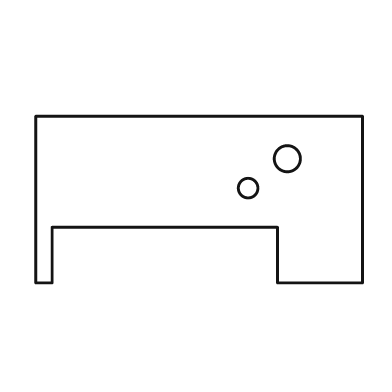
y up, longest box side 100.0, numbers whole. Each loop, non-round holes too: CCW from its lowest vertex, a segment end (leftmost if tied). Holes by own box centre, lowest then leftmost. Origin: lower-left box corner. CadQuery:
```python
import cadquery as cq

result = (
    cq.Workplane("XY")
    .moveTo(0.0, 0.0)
    .lineTo(5.0, 0.0)
    .lineTo(5.0, 17.0)
    .lineTo(74.0, 17.0)
    .lineTo(74.0, 0.0)
    .lineTo(100.0, 0.0)
    .lineTo(100.0, 51.0)
    .lineTo(0.0, 51.0)
    .close()
    .moveTo(65.0, 29.0)
    .circle(3.0)
    .moveTo(77.0, 38.0)
    .circle(4.0)
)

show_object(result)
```